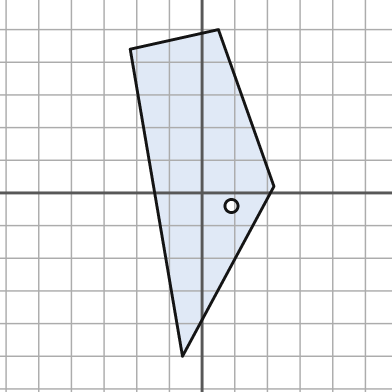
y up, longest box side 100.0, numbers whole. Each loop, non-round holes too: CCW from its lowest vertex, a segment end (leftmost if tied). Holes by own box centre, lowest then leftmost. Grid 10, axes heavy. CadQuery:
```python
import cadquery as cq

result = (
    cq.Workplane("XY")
    .moveTo(-6.0, -50.0)
    .lineTo(22.0, 2.0)
    .lineTo(5.0, 50.0)
    .lineTo(-22.0, 44.0)
    .close()
    .moveTo(9.0, -4.0)
    .circle(2.0)
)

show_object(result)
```